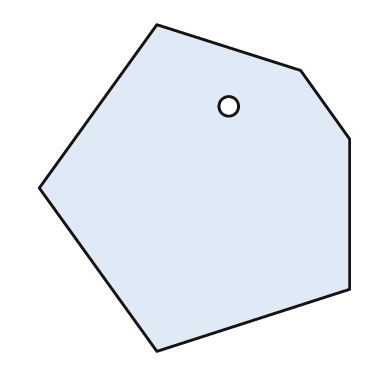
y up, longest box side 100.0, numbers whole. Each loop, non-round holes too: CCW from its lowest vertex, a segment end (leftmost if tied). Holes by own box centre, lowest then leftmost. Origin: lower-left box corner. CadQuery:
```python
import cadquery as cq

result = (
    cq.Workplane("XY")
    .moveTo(36.0, 0.0)
    .lineTo(95.0, 19.0)
    .lineTo(95.0, 65.0)
    .lineTo(80.0, 86.0)
    .lineTo(36.0, 100.0)
    .lineTo(0.0, 50.0)
    .close()
    .moveTo(58.0, 75.0)
    .circle(3.0)
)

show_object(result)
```